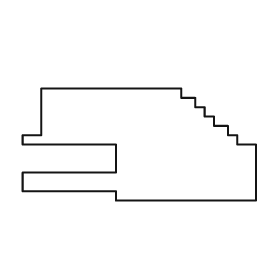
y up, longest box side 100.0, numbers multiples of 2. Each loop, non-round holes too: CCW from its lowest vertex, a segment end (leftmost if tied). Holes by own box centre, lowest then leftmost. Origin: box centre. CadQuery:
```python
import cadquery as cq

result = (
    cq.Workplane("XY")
    .moveTo(-10.0, -24.0)
    .lineTo(50.0, -24.0)
    .lineTo(50.0, 0.0)
    .lineTo(42.0, 0.0)
    .lineTo(42.0, 4.0)
    .lineTo(38.0, 4.0)
    .lineTo(38.0, 8.0)
    .lineTo(32.0, 8.0)
    .lineTo(32.0, 12.0)
    .lineTo(28.0, 12.0)
    .lineTo(28.0, 16.0)
    .lineTo(24.0, 16.0)
    .lineTo(24.0, 20.0)
    .lineTo(18.0, 20.0)
    .lineTo(18.0, 24.0)
    .lineTo(-42.0, 24.0)
    .lineTo(-42.0, 4.0)
    .lineTo(-50.0, 4.0)
    .lineTo(-50.0, 0.0)
    .lineTo(-10.0, 0.0)
    .lineTo(-10.0, -12.0)
    .lineTo(-50.0, -12.0)
    .lineTo(-50.0, -20.0)
    .lineTo(-10.0, -20.0)
    .close()
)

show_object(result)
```